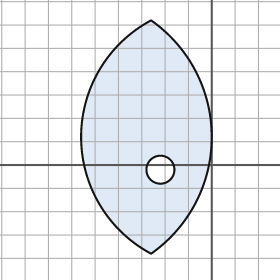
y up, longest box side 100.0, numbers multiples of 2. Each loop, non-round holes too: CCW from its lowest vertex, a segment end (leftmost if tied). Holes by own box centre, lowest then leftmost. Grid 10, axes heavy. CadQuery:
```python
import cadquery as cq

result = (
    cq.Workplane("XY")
    .moveTo(-26.0, -38.0)
    .threePointArc((0.0, 12.0), (-26.0, 62.0))
    .threePointArc((-56.0, 12.0), (-26.0, -38.0))
    .close()
    .moveTo(-22.0, -2.0)
    .circle(6.0)
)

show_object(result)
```